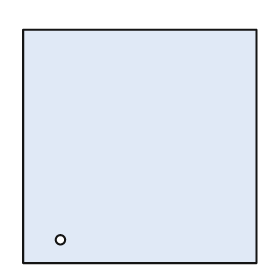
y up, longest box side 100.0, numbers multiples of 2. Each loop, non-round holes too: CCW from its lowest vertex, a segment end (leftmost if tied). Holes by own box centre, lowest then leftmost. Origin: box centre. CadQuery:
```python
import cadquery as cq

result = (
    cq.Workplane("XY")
    .moveTo(-50.0, -50.0)
    .lineTo(50.0, -50.0)
    .lineTo(50.0, 50.0)
    .lineTo(-50.0, 50.0)
    .close()
    .moveTo(-34.0, -40.0)
    .circle(2.0)
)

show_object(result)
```